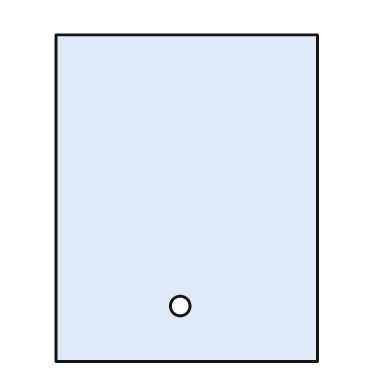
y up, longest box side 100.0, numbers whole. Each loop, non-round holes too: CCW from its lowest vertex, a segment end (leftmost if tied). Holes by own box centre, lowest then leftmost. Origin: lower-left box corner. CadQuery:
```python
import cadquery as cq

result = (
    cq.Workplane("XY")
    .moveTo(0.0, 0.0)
    .lineTo(80.0, 0.0)
    .lineTo(80.0, 100.0)
    .lineTo(0.0, 100.0)
    .close()
    .moveTo(38.0, 17.0)
    .circle(3.0)
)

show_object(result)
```